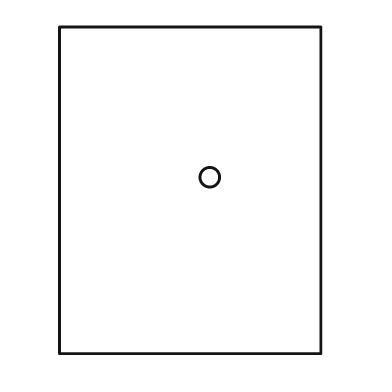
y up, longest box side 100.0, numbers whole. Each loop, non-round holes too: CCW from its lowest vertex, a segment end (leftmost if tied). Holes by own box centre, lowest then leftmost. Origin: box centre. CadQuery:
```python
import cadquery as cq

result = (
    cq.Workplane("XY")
    .moveTo(-40.0, -50.0)
    .lineTo(40.0, -50.0)
    .lineTo(40.0, 50.0)
    .lineTo(-40.0, 50.0)
    .close()
    .moveTo(6.0, 4.0)
    .circle(3.0)
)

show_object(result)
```